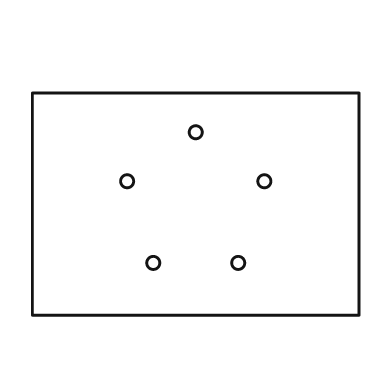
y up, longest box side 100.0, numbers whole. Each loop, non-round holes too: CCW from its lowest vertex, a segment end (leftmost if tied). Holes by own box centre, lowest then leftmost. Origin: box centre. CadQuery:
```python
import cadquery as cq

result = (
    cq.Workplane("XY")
    .moveTo(-50.0, -34.0)
    .lineTo(50.0, -34.0)
    .lineTo(50.0, 34.0)
    .lineTo(-50.0, 34.0)
    .close()
    .moveTo(-13.0, -18.0)
    .circle(2.0)
    .moveTo(13.0, -18.0)
    .circle(2.0)
    .moveTo(-21.0, 7.0)
    .circle(2.0)
    .moveTo(21.0, 7.0)
    .circle(2.0)
    .moveTo(0.0, 22.0)
    .circle(2.0)
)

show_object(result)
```